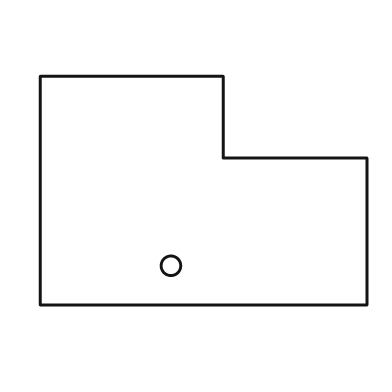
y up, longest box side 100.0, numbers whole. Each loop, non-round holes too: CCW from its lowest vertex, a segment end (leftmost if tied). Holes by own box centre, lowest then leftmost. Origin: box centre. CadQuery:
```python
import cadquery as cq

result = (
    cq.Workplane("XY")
    .moveTo(-50.0, -35.0)
    .lineTo(50.0, -35.0)
    .lineTo(50.0, 10.0)
    .lineTo(6.0, 10.0)
    .lineTo(6.0, 35.0)
    .lineTo(-50.0, 35.0)
    .close()
    .moveTo(-10.0, -23.0)
    .circle(3.0)
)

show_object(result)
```